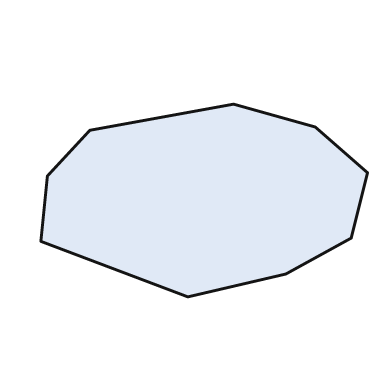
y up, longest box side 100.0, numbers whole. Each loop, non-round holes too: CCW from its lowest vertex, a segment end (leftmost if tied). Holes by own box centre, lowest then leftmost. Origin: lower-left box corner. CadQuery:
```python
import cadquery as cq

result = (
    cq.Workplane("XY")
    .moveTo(45.0, 0.0)
    .lineTo(75.0, 7.0)
    .lineTo(95.0, 18.0)
    .lineTo(100.0, 38.0)
    .lineTo(84.0, 52.0)
    .lineTo(59.0, 59.0)
    .lineTo(15.0, 51.0)
    .lineTo(2.0, 37.0)
    .lineTo(0.0, 17.0)
    .close()
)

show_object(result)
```